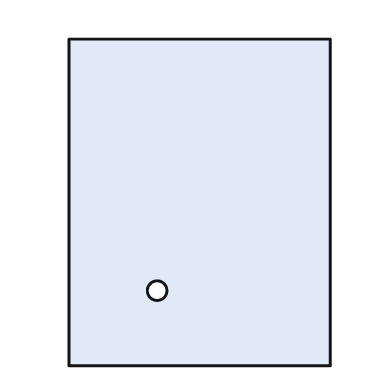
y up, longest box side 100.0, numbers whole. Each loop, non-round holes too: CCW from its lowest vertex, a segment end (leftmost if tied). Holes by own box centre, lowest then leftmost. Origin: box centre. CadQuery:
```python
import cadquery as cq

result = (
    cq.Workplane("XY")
    .moveTo(-40.0, -50.0)
    .lineTo(40.0, -50.0)
    .lineTo(40.0, 50.0)
    .lineTo(-40.0, 50.0)
    .close()
    .moveTo(-13.0, -27.0)
    .circle(3.0)
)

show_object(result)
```